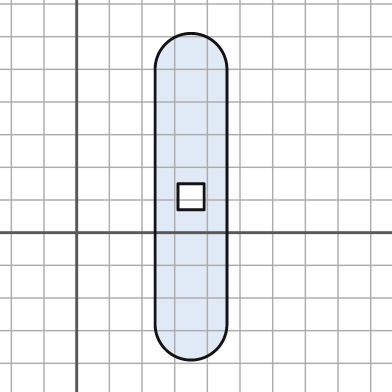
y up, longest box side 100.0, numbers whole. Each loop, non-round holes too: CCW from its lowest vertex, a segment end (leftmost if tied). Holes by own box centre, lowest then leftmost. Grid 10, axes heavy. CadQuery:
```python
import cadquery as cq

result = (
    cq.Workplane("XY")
    .moveTo(24.0, -28.0)
    .threePointArc((35.0, -39.0), (46.0, -28.0))
    .lineTo(46.0, 50.0)
    .threePointArc((35.0, 61.0), (24.0, 50.0))
    .close()
    .moveTo(31.0, 7.0)
    .lineTo(39.0, 7.0)
    .lineTo(39.0, 15.0)
    .lineTo(31.0, 15.0)
    .close()
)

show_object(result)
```